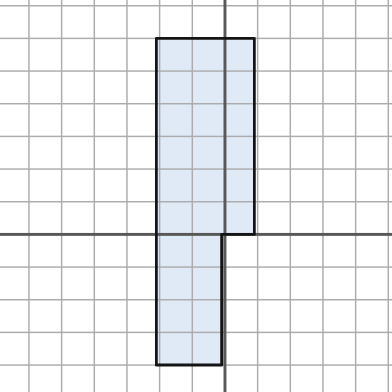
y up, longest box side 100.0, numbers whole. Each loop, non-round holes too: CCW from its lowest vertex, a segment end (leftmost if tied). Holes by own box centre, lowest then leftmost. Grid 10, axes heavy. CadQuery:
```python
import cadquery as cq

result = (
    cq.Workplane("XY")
    .moveTo(-21.0, -40.0)
    .lineTo(-1.0, -40.0)
    .lineTo(-1.0, 0.0)
    .lineTo(9.0, 0.0)
    .lineTo(9.0, 60.0)
    .lineTo(-21.0, 60.0)
    .close()
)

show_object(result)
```